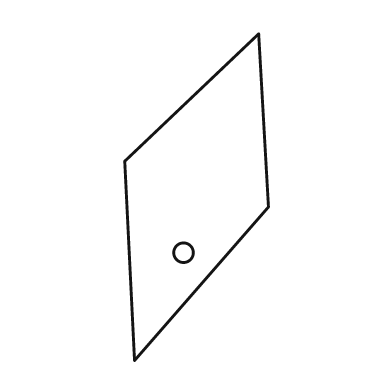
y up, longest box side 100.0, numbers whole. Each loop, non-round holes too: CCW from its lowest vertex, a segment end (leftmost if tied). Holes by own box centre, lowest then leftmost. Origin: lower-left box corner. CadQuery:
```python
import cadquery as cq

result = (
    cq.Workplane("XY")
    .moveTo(3.0, 0.0)
    .lineTo(44.0, 47.0)
    .lineTo(41.0, 100.0)
    .lineTo(0.0, 61.0)
    .close()
    .moveTo(18.0, 33.0)
    .circle(3.0)
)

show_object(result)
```